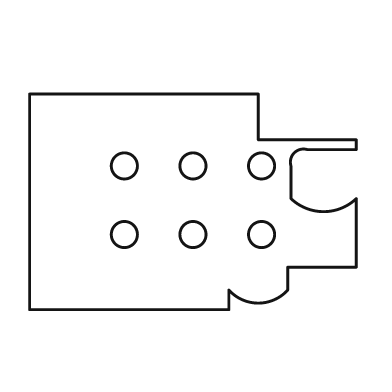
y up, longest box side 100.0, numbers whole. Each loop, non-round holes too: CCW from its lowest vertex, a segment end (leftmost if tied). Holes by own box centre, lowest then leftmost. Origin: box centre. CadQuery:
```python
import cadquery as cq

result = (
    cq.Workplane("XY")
    .moveTo(-50.0, -33.0)
    .lineTo(11.0, -33.0)
    .lineTo(11.0, -27.0)
    .threePointArc((20.0, -31.0), (29.0, -27.0))
    .lineTo(29.0, -20.0)
    .lineTo(50.0, -20.0)
    .lineTo(50.0, 1.0)
    .threePointArc((40.0, -3.0), (30.0, 1.0))
    .lineTo(30.0, 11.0)
    .threePointArc((31.0, 15.0), (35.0, 16.0))
    .lineTo(50.0, 16.0)
    .lineTo(50.0, 19.0)
    .lineTo(20.0, 19.0)
    .lineTo(20.0, 33.0)
    .lineTo(-50.0, 33.0)
    .close()
    .moveTo(-21.0, -10.0)
    .circle(4.0)
    .moveTo(0.0, -10.0)
    .circle(4.0)
    .moveTo(21.0, -10.0)
    .circle(4.0)
    .moveTo(-21.0, 11.0)
    .circle(4.0)
    .moveTo(0.0, 11.0)
    .circle(4.0)
    .moveTo(21.0, 11.0)
    .circle(4.0)
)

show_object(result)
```